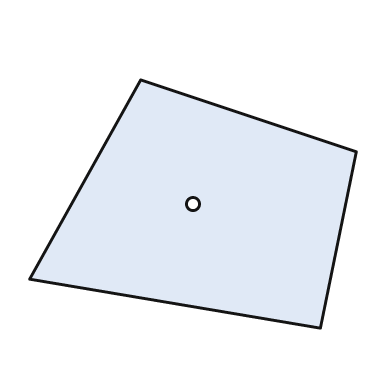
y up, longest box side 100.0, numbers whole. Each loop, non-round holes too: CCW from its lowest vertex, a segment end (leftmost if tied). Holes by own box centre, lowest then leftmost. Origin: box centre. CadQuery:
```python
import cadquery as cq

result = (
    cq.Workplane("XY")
    .moveTo(39.0, -38.0)
    .lineTo(50.0, 16.0)
    .lineTo(-16.0, 38.0)
    .lineTo(-50.0, -23.0)
    .close()
    .moveTo(0.0, 0.0)
    .circle(2.0)
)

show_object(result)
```